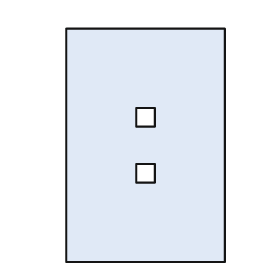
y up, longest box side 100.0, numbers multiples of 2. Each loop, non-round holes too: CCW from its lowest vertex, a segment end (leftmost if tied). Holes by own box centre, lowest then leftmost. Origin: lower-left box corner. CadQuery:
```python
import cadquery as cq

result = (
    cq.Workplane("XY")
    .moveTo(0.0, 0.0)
    .lineTo(68.0, 0.0)
    .lineTo(68.0, 100.0)
    .lineTo(0.0, 100.0)
    .close()
    .moveTo(30.0, 34.0)
    .lineTo(38.0, 34.0)
    .lineTo(38.0, 42.0)
    .lineTo(30.0, 42.0)
    .close()
    .moveTo(30.0, 58.0)
    .lineTo(38.0, 58.0)
    .lineTo(38.0, 66.0)
    .lineTo(30.0, 66.0)
    .close()
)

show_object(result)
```